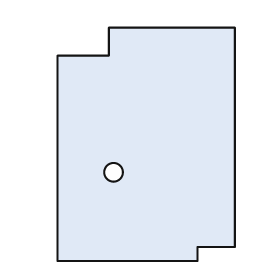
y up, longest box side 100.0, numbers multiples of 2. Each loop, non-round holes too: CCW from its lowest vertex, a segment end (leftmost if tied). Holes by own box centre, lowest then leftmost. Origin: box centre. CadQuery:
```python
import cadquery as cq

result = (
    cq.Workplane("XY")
    .moveTo(-38.0, -50.0)
    .lineTo(22.0, -50.0)
    .lineTo(22.0, -44.0)
    .lineTo(38.0, -44.0)
    .lineTo(38.0, 50.0)
    .lineTo(-16.0, 50.0)
    .lineTo(-16.0, 38.0)
    .lineTo(-38.0, 38.0)
    .close()
    .moveTo(-14.0, -12.0)
    .circle(4.0)
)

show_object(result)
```